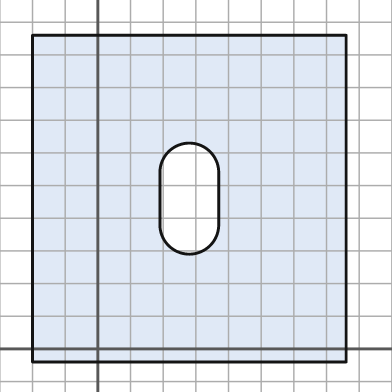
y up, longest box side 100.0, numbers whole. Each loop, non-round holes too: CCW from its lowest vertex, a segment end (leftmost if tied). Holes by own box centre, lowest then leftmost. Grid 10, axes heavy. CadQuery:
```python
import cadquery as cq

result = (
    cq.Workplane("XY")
    .moveTo(-20.0, -4.0)
    .lineTo(76.0, -4.0)
    .lineTo(76.0, 96.0)
    .lineTo(-20.0, 96.0)
    .close()
    .moveTo(19.0, 38.0)
    .threePointArc((28.0, 29.0), (37.0, 38.0))
    .lineTo(37.0, 54.0)
    .threePointArc((28.0, 63.0), (19.0, 54.0))
    .close()
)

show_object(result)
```